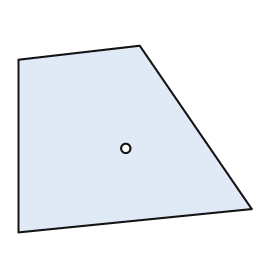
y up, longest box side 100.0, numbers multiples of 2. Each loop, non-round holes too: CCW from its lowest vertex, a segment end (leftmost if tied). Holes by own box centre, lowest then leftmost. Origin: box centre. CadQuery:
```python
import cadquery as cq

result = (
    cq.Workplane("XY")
    .moveTo(-50.0, -40.0)
    .lineTo(50.0, -30.0)
    .lineTo(2.0, 40.0)
    .lineTo(-50.0, 34.0)
    .close()
    .moveTo(-4.0, -4.0)
    .circle(2.0)
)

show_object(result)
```